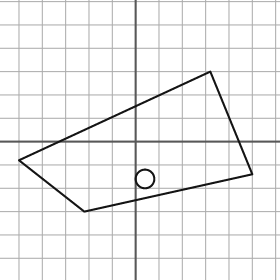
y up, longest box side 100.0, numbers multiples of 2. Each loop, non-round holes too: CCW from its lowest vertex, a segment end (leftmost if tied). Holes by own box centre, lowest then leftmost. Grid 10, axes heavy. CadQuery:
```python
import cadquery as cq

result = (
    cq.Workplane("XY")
    .moveTo(-22.0, -30.0)
    .lineTo(50.0, -14.0)
    .lineTo(32.0, 30.0)
    .lineTo(-50.0, -8.0)
    .close()
    .moveTo(4.0, -16.0)
    .circle(4.0)
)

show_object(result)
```